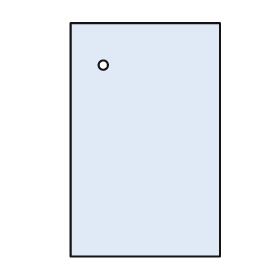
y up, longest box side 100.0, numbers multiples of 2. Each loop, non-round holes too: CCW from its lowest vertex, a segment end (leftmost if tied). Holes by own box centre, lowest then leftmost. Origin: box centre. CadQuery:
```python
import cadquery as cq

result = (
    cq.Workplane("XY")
    .moveTo(-32.0, -50.0)
    .lineTo(32.0, -50.0)
    .lineTo(32.0, 50.0)
    .lineTo(-32.0, 50.0)
    .close()
    .moveTo(-18.0, 32.0)
    .circle(2.0)
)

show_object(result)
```